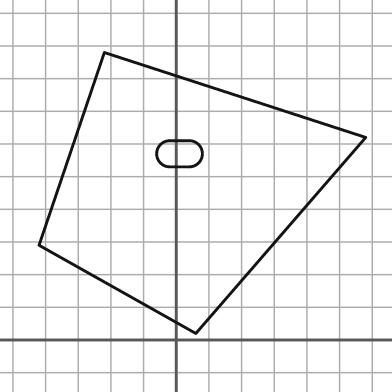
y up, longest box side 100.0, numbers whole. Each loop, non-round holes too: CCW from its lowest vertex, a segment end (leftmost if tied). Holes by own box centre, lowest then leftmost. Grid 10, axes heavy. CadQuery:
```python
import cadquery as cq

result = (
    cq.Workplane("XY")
    .moveTo(6.0, 2.0)
    .lineTo(58.0, 62.0)
    .lineTo(-22.0, 88.0)
    .lineTo(-42.0, 29.0)
    .close()
    .moveTo(-2.0, 53.0)
    .lineTo(4.0, 53.0)
    .threePointArc((8.0, 57.0), (4.0, 61.0))
    .lineTo(-2.0, 61.0)
    .threePointArc((-6.0, 57.0), (-2.0, 53.0))
    .close()
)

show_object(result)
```